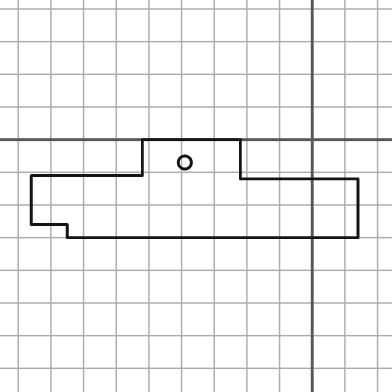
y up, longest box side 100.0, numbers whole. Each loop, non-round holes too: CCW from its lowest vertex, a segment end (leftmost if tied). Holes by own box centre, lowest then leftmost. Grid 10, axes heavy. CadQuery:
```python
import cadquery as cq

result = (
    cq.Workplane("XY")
    .moveTo(-75.0, -30.0)
    .lineTo(14.0, -30.0)
    .lineTo(14.0, -12.0)
    .lineTo(-22.0, -12.0)
    .lineTo(-22.0, 0.0)
    .lineTo(-52.0, 0.0)
    .lineTo(-52.0, -11.0)
    .lineTo(-86.0, -11.0)
    .lineTo(-86.0, -26.0)
    .lineTo(-75.0, -26.0)
    .close()
    .moveTo(-39.0, -7.0)
    .circle(2.0)
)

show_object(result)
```